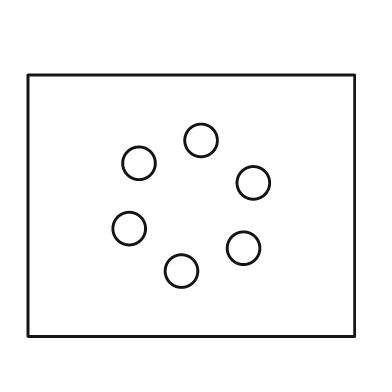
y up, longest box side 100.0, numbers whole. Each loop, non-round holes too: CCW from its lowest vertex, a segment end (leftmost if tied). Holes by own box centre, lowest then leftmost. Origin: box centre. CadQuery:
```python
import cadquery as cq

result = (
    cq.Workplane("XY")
    .moveTo(-50.0, -40.0)
    .lineTo(50.0, -40.0)
    .lineTo(50.0, 40.0)
    .lineTo(-50.0, 40.0)
    .close()
    .moveTo(-3.0, -20.0)
    .circle(5.0)
    .moveTo(16.0, -13.0)
    .circle(5.0)
    .moveTo(-19.0, -7.0)
    .circle(5.0)
    .moveTo(19.0, 7.0)
    .circle(5.0)
    .moveTo(-16.0, 13.0)
    .circle(5.0)
    .moveTo(3.0, 20.0)
    .circle(5.0)
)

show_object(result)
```